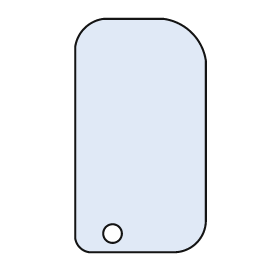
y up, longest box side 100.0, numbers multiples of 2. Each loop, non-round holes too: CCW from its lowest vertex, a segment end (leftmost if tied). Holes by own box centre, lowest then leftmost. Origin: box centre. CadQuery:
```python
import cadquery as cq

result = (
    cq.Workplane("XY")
    .moveTo(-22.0, -50.0)
    .lineTo(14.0, -50.0)
    .threePointArc((24.0, -46.0), (28.0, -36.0))
    .lineTo(28.0, 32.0)
    .threePointArc((22.0, 44.0), (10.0, 50.0))
    .lineTo(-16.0, 50.0)
    .threePointArc((-24.0, 46.0), (-28.0, 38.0))
    .lineTo(-28.0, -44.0)
    .threePointArc((-26.0, -48.0), (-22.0, -50.0))
    .close()
    .moveTo(-12.0, -42.0)
    .circle(4.0)
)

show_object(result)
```